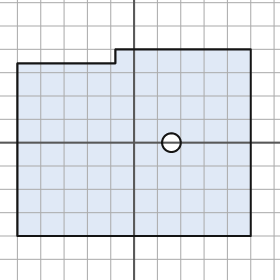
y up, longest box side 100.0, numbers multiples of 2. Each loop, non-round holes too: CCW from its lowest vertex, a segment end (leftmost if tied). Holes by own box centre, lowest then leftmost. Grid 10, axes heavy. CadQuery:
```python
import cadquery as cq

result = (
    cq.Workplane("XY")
    .moveTo(-50.0, -40.0)
    .lineTo(50.0, -40.0)
    .lineTo(50.0, 40.0)
    .lineTo(-8.0, 40.0)
    .lineTo(-8.0, 34.0)
    .lineTo(-50.0, 34.0)
    .close()
    .moveTo(16.0, 0.0)
    .circle(4.0)
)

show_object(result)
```